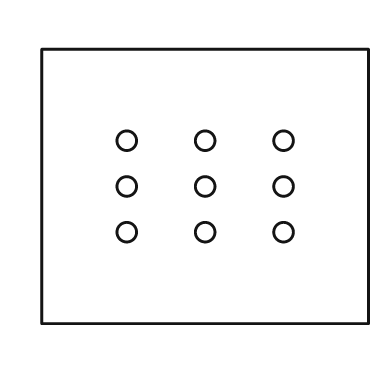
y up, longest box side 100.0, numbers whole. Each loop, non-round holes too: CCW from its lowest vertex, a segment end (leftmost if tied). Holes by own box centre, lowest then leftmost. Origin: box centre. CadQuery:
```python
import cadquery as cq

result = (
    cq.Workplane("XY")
    .moveTo(-50.0, -42.0)
    .lineTo(50.0, -42.0)
    .lineTo(50.0, 42.0)
    .lineTo(-50.0, 42.0)
    .close()
    .moveTo(-24.0, -14.0)
    .circle(3.0)
    .moveTo(0.0, -14.0)
    .circle(3.0)
    .moveTo(24.0, -14.0)
    .circle(3.0)
    .moveTo(-24.0, 0.0)
    .circle(3.0)
    .moveTo(0.0, 0.0)
    .circle(3.0)
    .moveTo(24.0, 0.0)
    .circle(3.0)
    .moveTo(-24.0, 14.0)
    .circle(3.0)
    .moveTo(0.0, 14.0)
    .circle(3.0)
    .moveTo(24.0, 14.0)
    .circle(3.0)
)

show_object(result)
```